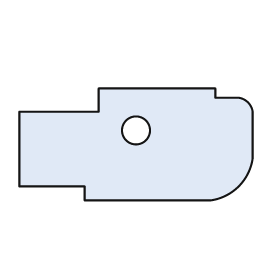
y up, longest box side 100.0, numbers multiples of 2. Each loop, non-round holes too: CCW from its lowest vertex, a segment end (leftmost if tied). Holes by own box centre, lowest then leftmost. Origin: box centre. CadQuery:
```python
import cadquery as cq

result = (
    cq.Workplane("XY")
    .moveTo(-22.0, -24.0)
    .lineTo(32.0, -24.0)
    .threePointArc((44.0, -18.0), (50.0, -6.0))
    .lineTo(50.0, 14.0)
    .threePointArc((48.0, 18.0), (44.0, 20.0))
    .lineTo(34.0, 20.0)
    .lineTo(34.0, 24.0)
    .lineTo(-16.0, 24.0)
    .lineTo(-16.0, 14.0)
    .lineTo(-50.0, 14.0)
    .lineTo(-50.0, -18.0)
    .lineTo(-22.0, -18.0)
    .close()
    .moveTo(0.0, 6.0)
    .circle(6.0)
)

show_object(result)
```